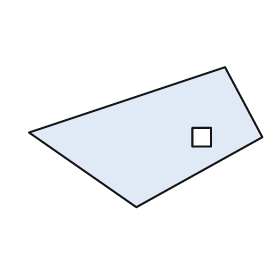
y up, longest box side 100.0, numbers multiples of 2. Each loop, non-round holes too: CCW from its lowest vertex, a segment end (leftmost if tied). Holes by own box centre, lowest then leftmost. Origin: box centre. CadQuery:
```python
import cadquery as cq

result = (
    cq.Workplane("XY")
    .moveTo(-4.0, -30.0)
    .lineTo(50.0, 0.0)
    .lineTo(34.0, 30.0)
    .lineTo(-50.0, 2.0)
    .close()
    .moveTo(20.0, -4.0)
    .lineTo(28.0, -4.0)
    .lineTo(28.0, 4.0)
    .lineTo(20.0, 4.0)
    .close()
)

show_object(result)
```